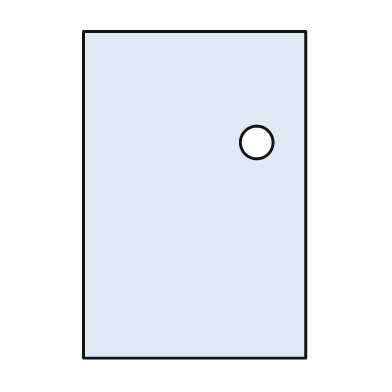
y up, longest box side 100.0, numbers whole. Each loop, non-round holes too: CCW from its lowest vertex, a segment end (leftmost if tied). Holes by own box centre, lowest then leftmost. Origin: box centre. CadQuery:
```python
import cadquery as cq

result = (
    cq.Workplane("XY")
    .moveTo(-34.0, -50.0)
    .lineTo(34.0, -50.0)
    .lineTo(34.0, 50.0)
    .lineTo(-34.0, 50.0)
    .close()
    .moveTo(19.0, 16.0)
    .circle(5.0)
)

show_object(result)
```